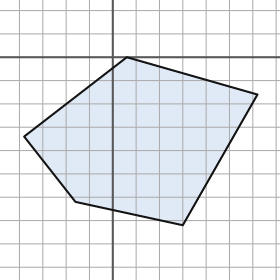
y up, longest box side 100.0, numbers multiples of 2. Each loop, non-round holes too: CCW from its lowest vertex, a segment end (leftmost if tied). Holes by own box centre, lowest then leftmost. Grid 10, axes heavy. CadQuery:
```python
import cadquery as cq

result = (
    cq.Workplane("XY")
    .moveTo(30.0, -72.0)
    .lineTo(62.0, -16.0)
    .lineTo(6.0, 0.0)
    .lineTo(-38.0, -34.0)
    .lineTo(-16.0, -62.0)
    .close()
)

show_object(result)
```